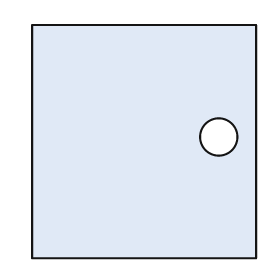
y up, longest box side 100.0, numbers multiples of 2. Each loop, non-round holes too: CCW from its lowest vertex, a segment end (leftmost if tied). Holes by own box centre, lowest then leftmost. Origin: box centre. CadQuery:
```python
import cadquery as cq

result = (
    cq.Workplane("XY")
    .moveTo(-48.0, -50.0)
    .lineTo(48.0, -50.0)
    .lineTo(48.0, 50.0)
    .lineTo(-48.0, 50.0)
    .close()
    .moveTo(32.0, 2.0)
    .circle(8.0)
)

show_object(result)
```